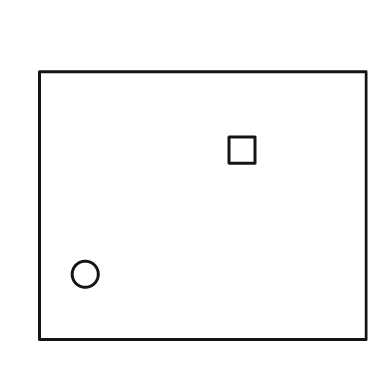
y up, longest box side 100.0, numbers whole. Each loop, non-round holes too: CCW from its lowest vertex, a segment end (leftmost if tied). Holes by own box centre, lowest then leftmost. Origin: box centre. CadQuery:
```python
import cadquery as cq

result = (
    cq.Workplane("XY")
    .moveTo(-50.0, -41.0)
    .lineTo(50.0, -41.0)
    .lineTo(50.0, 41.0)
    .lineTo(-50.0, 41.0)
    .close()
    .moveTo(-36.0, -21.0)
    .circle(4.0)
    .moveTo(8.0, 13.0)
    .lineTo(16.0, 13.0)
    .lineTo(16.0, 21.0)
    .lineTo(8.0, 21.0)
    .close()
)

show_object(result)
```